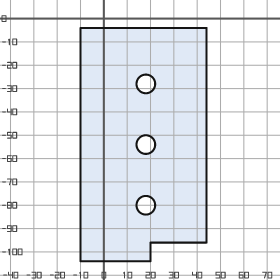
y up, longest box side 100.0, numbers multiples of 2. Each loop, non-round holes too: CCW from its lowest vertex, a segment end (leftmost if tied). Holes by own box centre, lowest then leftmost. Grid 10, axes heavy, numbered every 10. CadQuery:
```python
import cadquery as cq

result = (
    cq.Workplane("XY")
    .moveTo(-10.0, -104.0)
    .lineTo(20.0, -104.0)
    .lineTo(20.0, -96.0)
    .lineTo(44.0, -96.0)
    .lineTo(44.0, -4.0)
    .lineTo(-10.0, -4.0)
    .close()
    .moveTo(18.0, -80.0)
    .circle(4.0)
    .moveTo(18.0, -54.0)
    .circle(4.0)
    .moveTo(18.0, -28.0)
    .circle(4.0)
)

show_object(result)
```